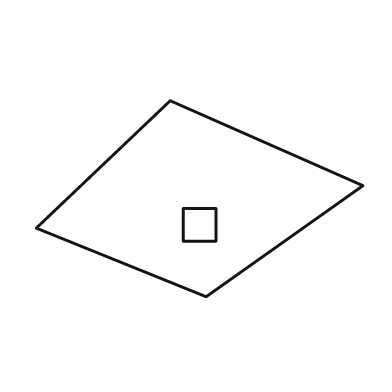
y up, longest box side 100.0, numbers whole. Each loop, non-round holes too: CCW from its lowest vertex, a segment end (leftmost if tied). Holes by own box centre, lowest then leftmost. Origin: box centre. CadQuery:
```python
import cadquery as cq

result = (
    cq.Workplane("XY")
    .moveTo(2.0, -30.0)
    .lineTo(50.0, 4.0)
    .lineTo(-9.0, 30.0)
    .lineTo(-50.0, -9.0)
    .close()
    .moveTo(-5.0, -13.0)
    .lineTo(5.0, -13.0)
    .lineTo(5.0, -3.0)
    .lineTo(-5.0, -3.0)
    .close()
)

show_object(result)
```